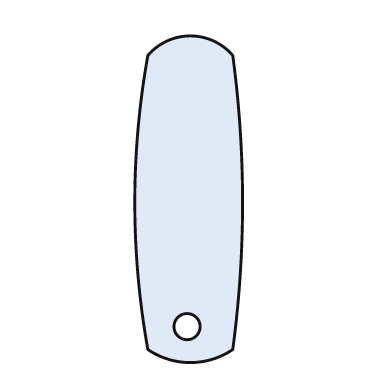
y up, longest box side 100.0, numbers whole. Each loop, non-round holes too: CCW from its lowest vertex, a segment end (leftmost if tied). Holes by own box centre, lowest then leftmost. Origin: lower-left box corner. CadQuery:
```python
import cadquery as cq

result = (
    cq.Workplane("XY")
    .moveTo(4.0, 4.0)
    .threePointArc((17.0, 0.0), (30.0, 4.0))
    .threePointArc((33.0, 49.0), (30.0, 94.0))
    .threePointArc((17.0, 100.0), (4.0, 94.0))
    .threePointArc((0.0, 49.0), (4.0, 4.0))
    .close()
    .moveTo(16.0, 11.0)
    .circle(4.0)
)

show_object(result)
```